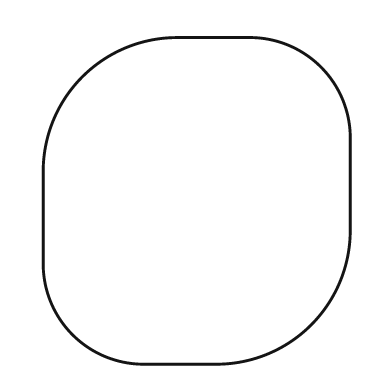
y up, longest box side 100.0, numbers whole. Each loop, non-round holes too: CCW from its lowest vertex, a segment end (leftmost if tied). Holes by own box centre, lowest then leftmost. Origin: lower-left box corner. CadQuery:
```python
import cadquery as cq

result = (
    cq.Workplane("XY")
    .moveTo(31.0, 0.0)
    .lineTo(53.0, 0.0)
    .threePointArc((82.0, 12.0), (94.0, 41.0))
    .lineTo(94.0, 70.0)
    .threePointArc((85.0, 91.0), (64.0, 100.0))
    .lineTo(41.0, 100.0)
    .threePointArc((12.0, 88.0), (0.0, 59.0))
    .lineTo(0.0, 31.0)
    .threePointArc((9.0, 9.0), (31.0, 0.0))
    .close()
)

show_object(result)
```